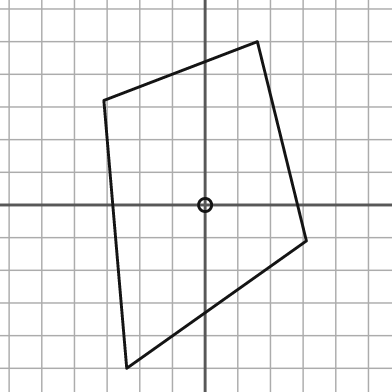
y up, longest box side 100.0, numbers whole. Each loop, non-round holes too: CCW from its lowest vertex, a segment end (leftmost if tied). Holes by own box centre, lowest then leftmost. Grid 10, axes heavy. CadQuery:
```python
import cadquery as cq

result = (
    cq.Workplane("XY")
    .moveTo(-24.0, -50.0)
    .lineTo(31.0, -11.0)
    .lineTo(16.0, 50.0)
    .lineTo(-31.0, 32.0)
    .close()
    .moveTo(0.0, 0.0)
    .circle(2.0)
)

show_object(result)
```